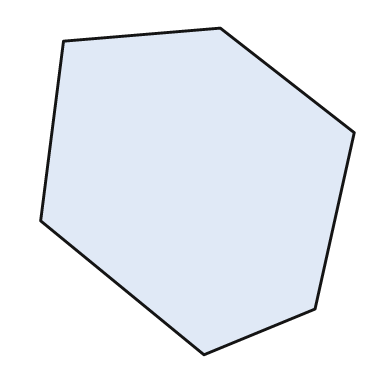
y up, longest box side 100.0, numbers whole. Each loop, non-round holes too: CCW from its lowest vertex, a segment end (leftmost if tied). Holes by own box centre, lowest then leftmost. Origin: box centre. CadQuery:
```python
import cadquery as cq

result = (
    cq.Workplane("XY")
    .moveTo(2.0, -50.0)
    .lineTo(36.0, -36.0)
    .lineTo(48.0, 18.0)
    .lineTo(7.0, 50.0)
    .lineTo(-41.0, 46.0)
    .lineTo(-48.0, -9.0)
    .close()
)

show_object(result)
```